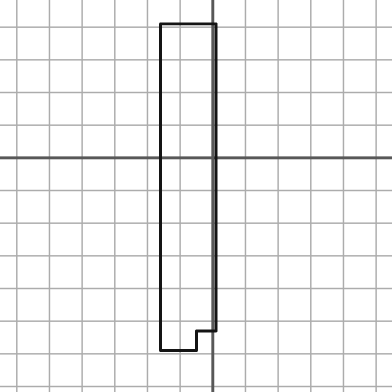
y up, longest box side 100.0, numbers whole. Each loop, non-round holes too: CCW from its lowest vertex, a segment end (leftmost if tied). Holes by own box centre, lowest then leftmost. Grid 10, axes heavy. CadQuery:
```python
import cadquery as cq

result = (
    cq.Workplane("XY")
    .moveTo(-16.0, -59.0)
    .lineTo(-5.0, -59.0)
    .lineTo(-5.0, -53.0)
    .lineTo(1.0, -53.0)
    .lineTo(1.0, 41.0)
    .lineTo(-16.0, 41.0)
    .close()
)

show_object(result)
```